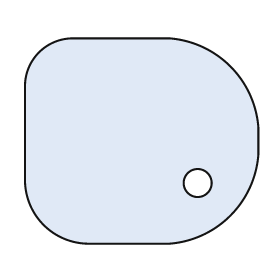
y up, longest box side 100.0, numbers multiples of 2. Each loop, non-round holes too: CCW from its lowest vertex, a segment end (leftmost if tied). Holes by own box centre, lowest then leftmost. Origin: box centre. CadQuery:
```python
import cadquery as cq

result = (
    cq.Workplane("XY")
    .moveTo(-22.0, -44.0)
    .lineTo(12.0, -44.0)
    .threePointArc((38.0, -32.0), (50.0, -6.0))
    .lineTo(50.0, 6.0)
    .threePointArc((38.0, 32.0), (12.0, 44.0))
    .lineTo(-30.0, 44.0)
    .threePointArc((-44.0, 38.0), (-50.0, 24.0))
    .lineTo(-50.0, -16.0)
    .threePointArc((-42.0, -36.0), (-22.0, -44.0))
    .close()
    .moveTo(24.0, -18.0)
    .circle(6.0)
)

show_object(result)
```